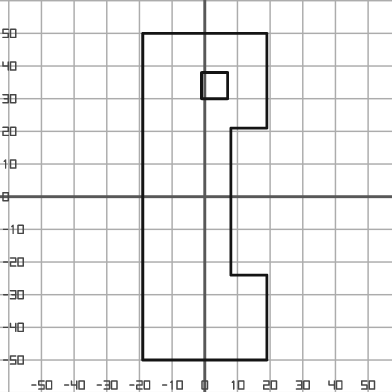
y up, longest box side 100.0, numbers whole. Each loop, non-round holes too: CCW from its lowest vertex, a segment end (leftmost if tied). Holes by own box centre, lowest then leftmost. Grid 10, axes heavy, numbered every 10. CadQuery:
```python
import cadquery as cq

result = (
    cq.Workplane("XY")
    .moveTo(-19.0, -50.0)
    .lineTo(19.0, -50.0)
    .lineTo(19.0, -24.0)
    .lineTo(8.0, -24.0)
    .lineTo(8.0, 21.0)
    .lineTo(19.0, 21.0)
    .lineTo(19.0, 50.0)
    .lineTo(-19.0, 50.0)
    .close()
    .moveTo(-1.0, 30.0)
    .lineTo(7.0, 30.0)
    .lineTo(7.0, 38.0)
    .lineTo(-1.0, 38.0)
    .close()
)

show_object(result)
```